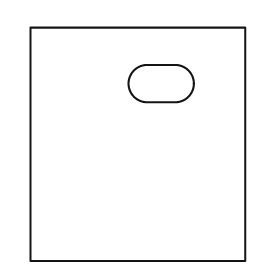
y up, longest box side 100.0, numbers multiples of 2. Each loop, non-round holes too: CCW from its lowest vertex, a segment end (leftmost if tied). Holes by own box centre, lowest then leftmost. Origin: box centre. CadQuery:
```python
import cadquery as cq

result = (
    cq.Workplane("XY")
    .moveTo(-46.0, -50.0)
    .lineTo(46.0, -50.0)
    .lineTo(46.0, 50.0)
    .lineTo(-46.0, 50.0)
    .close()
    .moveTo(4.0, 18.0)
    .lineTo(16.0, 18.0)
    .threePointArc((24.0, 26.0), (16.0, 34.0))
    .lineTo(4.0, 34.0)
    .threePointArc((-4.0, 26.0), (4.0, 18.0))
    .close()
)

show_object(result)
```